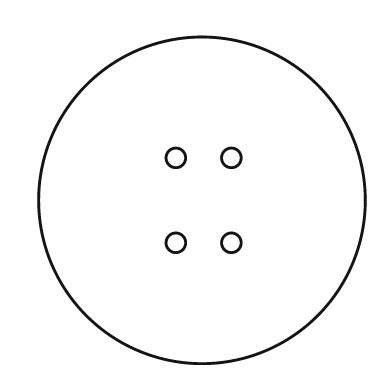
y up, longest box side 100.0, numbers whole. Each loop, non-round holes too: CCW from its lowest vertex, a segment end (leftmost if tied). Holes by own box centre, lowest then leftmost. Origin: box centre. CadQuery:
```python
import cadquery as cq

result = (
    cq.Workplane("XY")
    .moveTo(0.0, 0.0)
    .circle(50.0)
    .moveTo(-8.0, -13.0)
    .circle(3.0)
    .moveTo(9.0, -13.0)
    .circle(3.0)
    .moveTo(-8.0, 13.0)
    .circle(3.0)
    .moveTo(9.0, 13.0)
    .circle(3.0)
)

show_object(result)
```